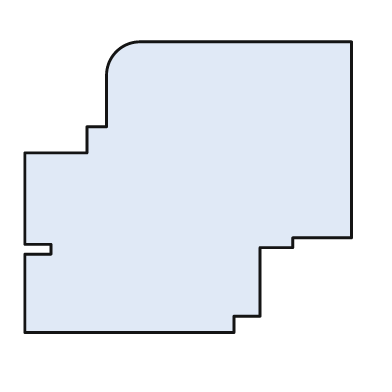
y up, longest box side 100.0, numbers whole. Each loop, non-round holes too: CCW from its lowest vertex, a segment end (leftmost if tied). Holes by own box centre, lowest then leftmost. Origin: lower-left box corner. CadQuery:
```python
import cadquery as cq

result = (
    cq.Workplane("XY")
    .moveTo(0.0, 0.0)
    .lineTo(64.0, 0.0)
    .lineTo(64.0, 5.0)
    .lineTo(72.0, 5.0)
    .lineTo(72.0, 26.0)
    .lineTo(82.0, 26.0)
    .lineTo(82.0, 29.0)
    .lineTo(100.0, 29.0)
    .lineTo(100.0, 89.0)
    .lineTo(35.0, 89.0)
    .threePointArc((28.0, 86.0), (25.0, 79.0))
    .lineTo(25.0, 63.0)
    .lineTo(19.0, 63.0)
    .lineTo(19.0, 55.0)
    .lineTo(0.0, 55.0)
    .lineTo(0.0, 27.0)
    .lineTo(8.0, 27.0)
    .lineTo(8.0, 24.0)
    .lineTo(0.0, 24.0)
    .close()
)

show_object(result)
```